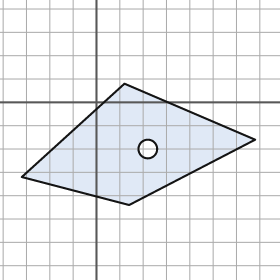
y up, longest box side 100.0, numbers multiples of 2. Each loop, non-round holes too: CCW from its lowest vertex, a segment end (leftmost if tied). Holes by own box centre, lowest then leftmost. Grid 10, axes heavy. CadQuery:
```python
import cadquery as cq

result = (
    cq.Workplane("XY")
    .moveTo(14.0, -44.0)
    .lineTo(68.0, -16.0)
    .lineTo(12.0, 8.0)
    .lineTo(-32.0, -32.0)
    .close()
    .moveTo(22.0, -20.0)
    .circle(4.0)
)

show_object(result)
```